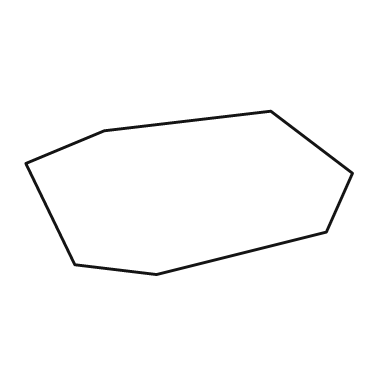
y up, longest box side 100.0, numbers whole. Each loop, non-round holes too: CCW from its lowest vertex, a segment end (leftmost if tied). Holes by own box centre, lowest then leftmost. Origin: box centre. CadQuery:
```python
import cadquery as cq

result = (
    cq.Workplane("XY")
    .moveTo(-10.0, -25.0)
    .lineTo(42.0, -12.0)
    .lineTo(50.0, 6.0)
    .lineTo(25.0, 25.0)
    .lineTo(-26.0, 19.0)
    .lineTo(-50.0, 9.0)
    .lineTo(-35.0, -22.0)
    .close()
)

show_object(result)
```